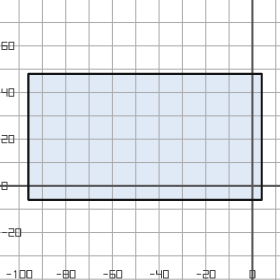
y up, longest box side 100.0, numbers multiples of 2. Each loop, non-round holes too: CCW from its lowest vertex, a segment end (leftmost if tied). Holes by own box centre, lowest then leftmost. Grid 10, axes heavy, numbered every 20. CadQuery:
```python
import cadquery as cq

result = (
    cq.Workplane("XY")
    .moveTo(-96.0, -6.0)
    .lineTo(4.0, -6.0)
    .lineTo(4.0, 48.0)
    .lineTo(-96.0, 48.0)
    .close()
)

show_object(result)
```